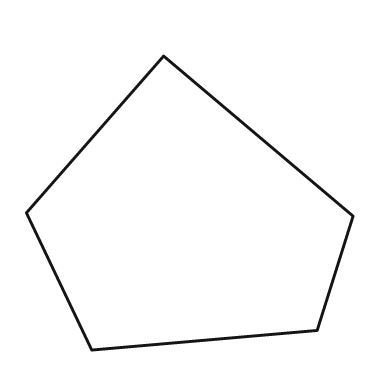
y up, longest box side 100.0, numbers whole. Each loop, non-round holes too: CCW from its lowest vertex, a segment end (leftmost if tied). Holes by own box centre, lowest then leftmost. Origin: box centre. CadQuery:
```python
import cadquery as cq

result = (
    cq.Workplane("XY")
    .moveTo(-30.0, -45.0)
    .lineTo(39.0, -39.0)
    .lineTo(50.0, -4.0)
    .lineTo(-8.0, 45.0)
    .lineTo(-50.0, -3.0)
    .close()
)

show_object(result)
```